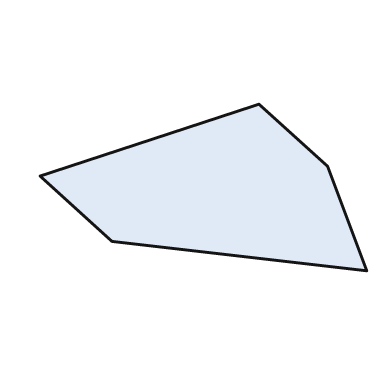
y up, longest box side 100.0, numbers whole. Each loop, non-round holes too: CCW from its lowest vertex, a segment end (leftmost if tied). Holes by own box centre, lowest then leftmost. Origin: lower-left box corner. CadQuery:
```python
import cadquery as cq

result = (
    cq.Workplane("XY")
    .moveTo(100.0, 0.0)
    .lineTo(88.0, 32.0)
    .lineTo(67.0, 51.0)
    .lineTo(0.0, 29.0)
    .lineTo(22.0, 9.0)
    .close()
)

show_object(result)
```